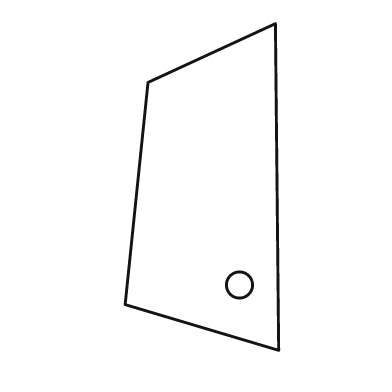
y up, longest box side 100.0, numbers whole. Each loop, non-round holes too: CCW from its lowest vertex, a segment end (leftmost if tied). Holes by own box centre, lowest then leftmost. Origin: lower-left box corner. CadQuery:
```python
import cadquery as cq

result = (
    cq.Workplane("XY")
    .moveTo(47.0, 0.0)
    .lineTo(46.0, 100.0)
    .lineTo(7.0, 82.0)
    .lineTo(0.0, 14.0)
    .close()
    .moveTo(35.0, 20.0)
    .circle(4.0)
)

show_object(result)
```